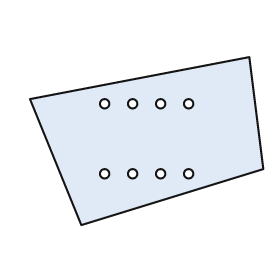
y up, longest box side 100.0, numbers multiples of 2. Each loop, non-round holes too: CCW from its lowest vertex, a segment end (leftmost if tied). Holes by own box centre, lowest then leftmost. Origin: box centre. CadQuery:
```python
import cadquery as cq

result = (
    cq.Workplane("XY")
    .moveTo(-28.0, -36.0)
    .lineTo(50.0, -12.0)
    .lineTo(44.0, 36.0)
    .lineTo(-50.0, 18.0)
    .close()
    .moveTo(-18.0, -14.0)
    .circle(2.0)
    .moveTo(-6.0, -14.0)
    .circle(2.0)
    .moveTo(6.0, -14.0)
    .circle(2.0)
    .moveTo(18.0, -14.0)
    .circle(2.0)
    .moveTo(-18.0, 16.0)
    .circle(2.0)
    .moveTo(-6.0, 16.0)
    .circle(2.0)
    .moveTo(6.0, 16.0)
    .circle(2.0)
    .moveTo(18.0, 16.0)
    .circle(2.0)
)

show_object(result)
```